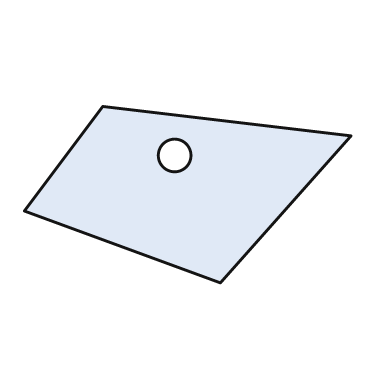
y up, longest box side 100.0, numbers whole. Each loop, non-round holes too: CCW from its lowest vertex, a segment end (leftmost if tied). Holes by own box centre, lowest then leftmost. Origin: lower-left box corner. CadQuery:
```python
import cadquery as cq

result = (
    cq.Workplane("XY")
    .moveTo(60.0, 0.0)
    .lineTo(100.0, 45.0)
    .lineTo(24.0, 54.0)
    .lineTo(0.0, 22.0)
    .close()
    .moveTo(46.0, 39.0)
    .circle(5.0)
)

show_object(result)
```